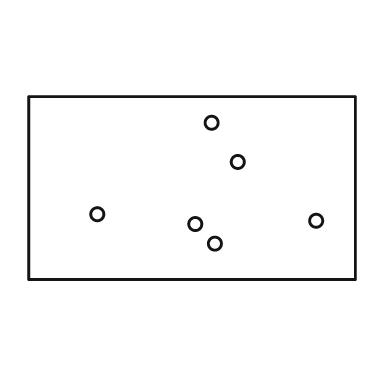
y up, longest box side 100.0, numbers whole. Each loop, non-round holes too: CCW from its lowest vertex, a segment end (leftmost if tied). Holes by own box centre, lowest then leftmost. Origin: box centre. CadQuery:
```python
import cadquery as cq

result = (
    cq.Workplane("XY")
    .moveTo(-50.0, -28.0)
    .lineTo(50.0, -28.0)
    .lineTo(50.0, 28.0)
    .lineTo(-50.0, 28.0)
    .close()
    .moveTo(7.0, -17.0)
    .circle(2.0)
    .moveTo(1.0, -11.0)
    .circle(2.0)
    .moveTo(38.0, -10.0)
    .circle(2.0)
    .moveTo(-29.0, -8.0)
    .circle(2.0)
    .moveTo(14.0, 8.0)
    .circle(2.0)
    .moveTo(6.0, 20.0)
    .circle(2.0)
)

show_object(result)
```